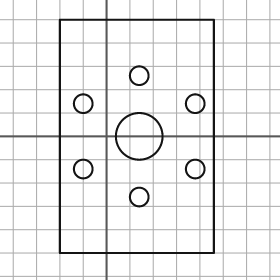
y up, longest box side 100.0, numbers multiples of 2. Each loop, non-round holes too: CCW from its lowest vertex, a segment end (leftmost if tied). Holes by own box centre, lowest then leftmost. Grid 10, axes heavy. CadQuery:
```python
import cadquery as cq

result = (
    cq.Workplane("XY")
    .moveTo(-20.0, -50.0)
    .lineTo(46.0, -50.0)
    .lineTo(46.0, 50.0)
    .lineTo(-20.0, 50.0)
    .close()
    .moveTo(14.0, -26.0)
    .circle(4.0)
    .moveTo(-10.0, -14.0)
    .circle(4.0)
    .moveTo(38.0, -14.0)
    .circle(4.0)
    .moveTo(14.0, 0.0)
    .circle(10.0)
    .moveTo(-10.0, 14.0)
    .circle(4.0)
    .moveTo(38.0, 14.0)
    .circle(4.0)
    .moveTo(14.0, 26.0)
    .circle(4.0)
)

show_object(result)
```